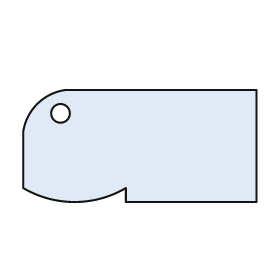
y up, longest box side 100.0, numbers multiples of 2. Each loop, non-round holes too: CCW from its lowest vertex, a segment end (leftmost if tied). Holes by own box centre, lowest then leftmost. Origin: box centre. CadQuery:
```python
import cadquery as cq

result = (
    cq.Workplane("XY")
    .moveTo(-6.0, -24.0)
    .lineTo(50.0, -24.0)
    .lineTo(50.0, 24.0)
    .lineTo(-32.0, 24.0)
    .threePointArc((-44.0, 18.0), (-50.0, 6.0))
    .lineTo(-50.0, -18.0)
    .threePointArc((-28.0, -24.0), (-6.0, -18.0))
    .close()
    .moveTo(-34.0, 14.0)
    .circle(4.0)
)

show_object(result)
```